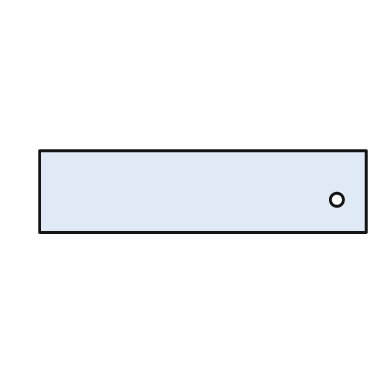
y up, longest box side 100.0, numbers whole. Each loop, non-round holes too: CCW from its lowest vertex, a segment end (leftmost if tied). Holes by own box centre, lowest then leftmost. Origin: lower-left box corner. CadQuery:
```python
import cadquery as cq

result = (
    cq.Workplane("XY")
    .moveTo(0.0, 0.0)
    .lineTo(100.0, 0.0)
    .lineTo(100.0, 25.0)
    .lineTo(0.0, 25.0)
    .close()
    .moveTo(91.0, 10.0)
    .circle(2.0)
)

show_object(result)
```